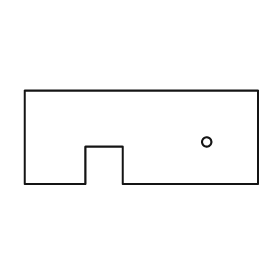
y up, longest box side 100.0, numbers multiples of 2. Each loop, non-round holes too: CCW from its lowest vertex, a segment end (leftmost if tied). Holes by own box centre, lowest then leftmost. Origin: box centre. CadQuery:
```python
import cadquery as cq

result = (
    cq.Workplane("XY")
    .moveTo(-50.0, -20.0)
    .lineTo(-24.0, -20.0)
    .lineTo(-24.0, -4.0)
    .lineTo(-8.0, -4.0)
    .lineTo(-8.0, -20.0)
    .lineTo(50.0, -20.0)
    .lineTo(50.0, 20.0)
    .lineTo(-50.0, 20.0)
    .close()
    .moveTo(28.0, -2.0)
    .circle(2.0)
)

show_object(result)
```